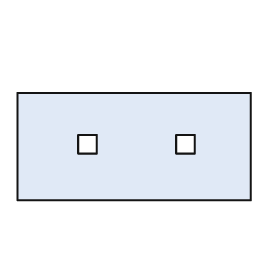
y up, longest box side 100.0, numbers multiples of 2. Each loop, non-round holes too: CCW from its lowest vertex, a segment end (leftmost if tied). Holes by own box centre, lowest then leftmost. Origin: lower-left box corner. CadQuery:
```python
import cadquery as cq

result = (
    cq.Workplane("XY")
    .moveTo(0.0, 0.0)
    .lineTo(100.0, 0.0)
    .lineTo(100.0, 46.0)
    .lineTo(0.0, 46.0)
    .close()
    .moveTo(26.0, 20.0)
    .lineTo(34.0, 20.0)
    .lineTo(34.0, 28.0)
    .lineTo(26.0, 28.0)
    .close()
    .moveTo(68.0, 20.0)
    .lineTo(76.0, 20.0)
    .lineTo(76.0, 28.0)
    .lineTo(68.0, 28.0)
    .close()
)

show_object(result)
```